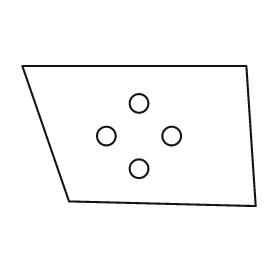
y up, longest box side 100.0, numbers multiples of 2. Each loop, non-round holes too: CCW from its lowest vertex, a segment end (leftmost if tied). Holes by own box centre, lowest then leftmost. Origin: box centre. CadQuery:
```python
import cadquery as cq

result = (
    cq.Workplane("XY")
    .moveTo(50.0, -30.0)
    .lineTo(46.0, 30.0)
    .lineTo(-50.0, 30.0)
    .lineTo(-30.0, -28.0)
    .close()
    .moveTo(0.0, -14.0)
    .circle(4.0)
    .moveTo(-14.0, 0.0)
    .circle(4.0)
    .moveTo(14.0, 0.0)
    .circle(4.0)
    .moveTo(0.0, 14.0)
    .circle(4.0)
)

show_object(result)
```